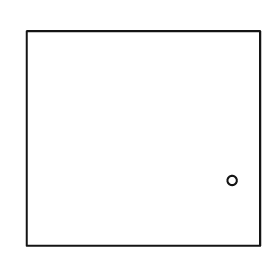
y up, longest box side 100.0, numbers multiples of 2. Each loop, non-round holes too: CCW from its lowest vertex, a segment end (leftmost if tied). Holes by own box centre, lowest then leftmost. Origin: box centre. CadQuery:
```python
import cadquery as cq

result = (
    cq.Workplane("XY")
    .moveTo(-50.0, -46.0)
    .lineTo(50.0, -46.0)
    .lineTo(50.0, 46.0)
    .lineTo(-50.0, 46.0)
    .close()
    .moveTo(38.0, -18.0)
    .circle(2.0)
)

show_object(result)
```